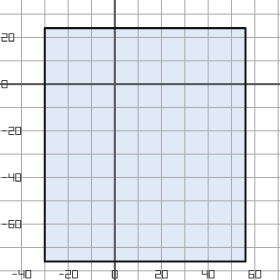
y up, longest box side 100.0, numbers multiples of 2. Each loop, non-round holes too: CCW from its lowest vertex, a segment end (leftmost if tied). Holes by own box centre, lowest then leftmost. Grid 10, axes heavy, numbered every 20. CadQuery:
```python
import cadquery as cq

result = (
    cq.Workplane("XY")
    .moveTo(-30.0, -76.0)
    .lineTo(56.0, -76.0)
    .lineTo(56.0, 24.0)
    .lineTo(-30.0, 24.0)
    .close()
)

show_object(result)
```